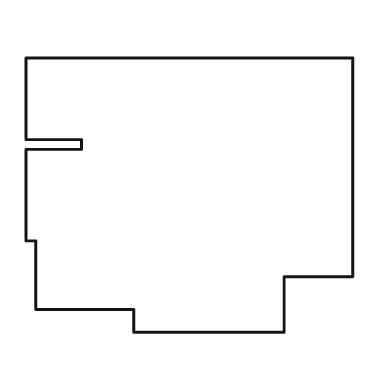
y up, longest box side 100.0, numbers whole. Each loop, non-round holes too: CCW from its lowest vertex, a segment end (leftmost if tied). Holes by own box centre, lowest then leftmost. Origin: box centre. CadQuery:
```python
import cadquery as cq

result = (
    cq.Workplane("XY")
    .moveTo(-17.0, -42.0)
    .lineTo(29.0, -42.0)
    .lineTo(29.0, -25.0)
    .lineTo(50.0, -25.0)
    .lineTo(50.0, 42.0)
    .lineTo(-50.0, 42.0)
    .lineTo(-50.0, 17.0)
    .lineTo(-33.0, 17.0)
    .lineTo(-33.0, 14.0)
    .lineTo(-50.0, 14.0)
    .lineTo(-50.0, -14.0)
    .lineTo(-47.0, -14.0)
    .lineTo(-47.0, -35.0)
    .lineTo(-17.0, -35.0)
    .close()
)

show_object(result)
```